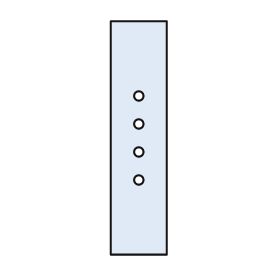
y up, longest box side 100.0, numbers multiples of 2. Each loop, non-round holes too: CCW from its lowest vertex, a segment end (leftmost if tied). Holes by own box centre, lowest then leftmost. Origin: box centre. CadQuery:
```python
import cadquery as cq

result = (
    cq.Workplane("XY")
    .moveTo(-12.0, -50.0)
    .lineTo(12.0, -50.0)
    .lineTo(12.0, 50.0)
    .lineTo(-12.0, 50.0)
    .close()
    .moveTo(0.0, -18.0)
    .circle(2.0)
    .moveTo(0.0, -6.0)
    .circle(2.0)
    .moveTo(0.0, 6.0)
    .circle(2.0)
    .moveTo(0.0, 18.0)
    .circle(2.0)
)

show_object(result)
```